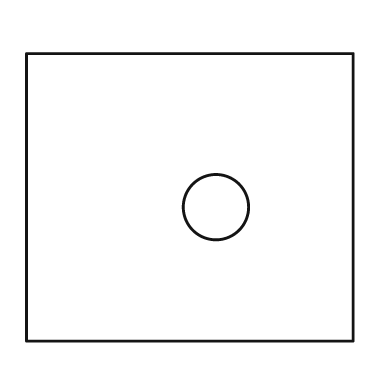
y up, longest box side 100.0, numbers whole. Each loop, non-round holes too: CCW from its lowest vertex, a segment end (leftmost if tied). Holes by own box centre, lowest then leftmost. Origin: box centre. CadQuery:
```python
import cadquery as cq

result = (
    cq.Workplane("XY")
    .moveTo(-50.0, -44.0)
    .lineTo(50.0, -44.0)
    .lineTo(50.0, 44.0)
    .lineTo(-50.0, 44.0)
    .close()
    .moveTo(8.0, -3.0)
    .circle(10.0)
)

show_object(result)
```